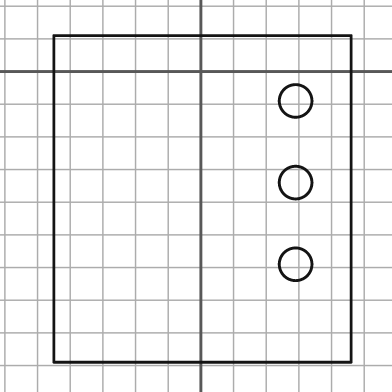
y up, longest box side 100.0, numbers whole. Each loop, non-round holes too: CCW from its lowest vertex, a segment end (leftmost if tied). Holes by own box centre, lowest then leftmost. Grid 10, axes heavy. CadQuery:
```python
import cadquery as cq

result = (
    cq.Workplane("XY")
    .moveTo(-45.0, -89.0)
    .lineTo(46.0, -89.0)
    .lineTo(46.0, 11.0)
    .lineTo(-45.0, 11.0)
    .close()
    .moveTo(29.0, -59.0)
    .circle(5.0)
    .moveTo(29.0, -34.0)
    .circle(5.0)
    .moveTo(29.0, -9.0)
    .circle(5.0)
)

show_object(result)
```